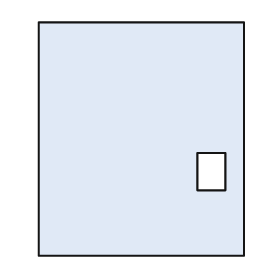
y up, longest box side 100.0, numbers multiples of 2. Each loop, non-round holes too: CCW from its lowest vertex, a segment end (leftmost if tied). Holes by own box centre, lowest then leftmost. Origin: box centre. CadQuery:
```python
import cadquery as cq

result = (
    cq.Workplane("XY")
    .moveTo(-44.0, -50.0)
    .lineTo(44.0, -50.0)
    .lineTo(44.0, 50.0)
    .lineTo(-44.0, 50.0)
    .close()
    .moveTo(24.0, -22.0)
    .lineTo(36.0, -22.0)
    .lineTo(36.0, -6.0)
    .lineTo(24.0, -6.0)
    .close()
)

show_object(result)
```